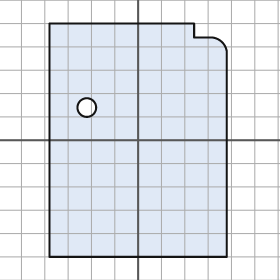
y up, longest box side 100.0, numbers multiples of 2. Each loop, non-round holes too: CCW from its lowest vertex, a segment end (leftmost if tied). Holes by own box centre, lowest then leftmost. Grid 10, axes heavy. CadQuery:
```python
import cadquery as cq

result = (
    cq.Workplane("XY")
    .moveTo(-38.0, -50.0)
    .lineTo(38.0, -50.0)
    .lineTo(38.0, 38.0)
    .threePointArc((36.0, 42.0), (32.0, 44.0))
    .lineTo(24.0, 44.0)
    .lineTo(24.0, 50.0)
    .lineTo(-38.0, 50.0)
    .close()
    .moveTo(-22.0, 14.0)
    .circle(4.0)
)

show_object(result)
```